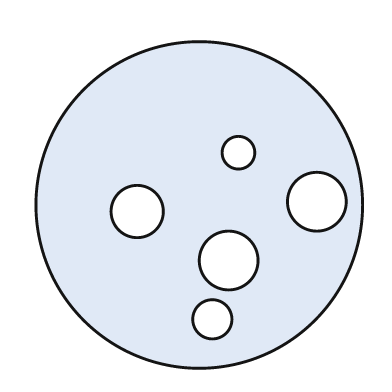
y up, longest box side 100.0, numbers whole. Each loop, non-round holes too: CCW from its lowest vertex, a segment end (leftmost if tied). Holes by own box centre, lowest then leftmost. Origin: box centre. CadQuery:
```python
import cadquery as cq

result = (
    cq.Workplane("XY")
    .moveTo(0.0, 0.0)
    .circle(50.0)
    .moveTo(4.0, -35.0)
    .circle(6.0)
    .moveTo(9.0, -17.0)
    .circle(9.0)
    .moveTo(-19.0, -2.0)
    .circle(8.0)
    .moveTo(36.0, 1.0)
    .circle(9.0)
    .moveTo(12.0, 16.0)
    .circle(5.0)
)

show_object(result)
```